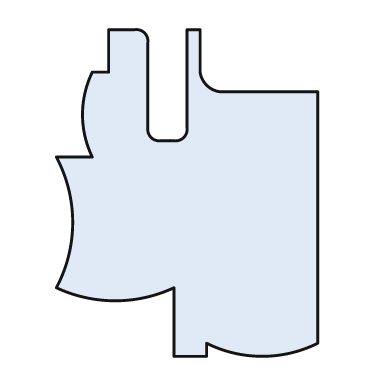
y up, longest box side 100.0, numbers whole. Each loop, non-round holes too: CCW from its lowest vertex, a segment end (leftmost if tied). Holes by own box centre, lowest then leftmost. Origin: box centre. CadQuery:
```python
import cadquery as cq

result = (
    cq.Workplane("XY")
    .moveTo(-4.0, -50.0)
    .lineTo(6.0, -50.0)
    .lineTo(6.0, -46.0)
    .threePointArc((23.0, -50.0), (40.0, -46.0))
    .lineTo(40.0, 31.0)
    .lineTo(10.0, 31.0)
    .threePointArc((6.0, 33.0), (4.0, 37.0))
    .lineTo(4.0, 50.0)
    .lineTo(0.0, 50.0)
    .lineTo(0.0, 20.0)
    .threePointArc((-1.0, 17.0), (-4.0, 16.0))
    .lineTo(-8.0, 16.0)
    .threePointArc((-11.0, 17.0), (-12.0, 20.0))
    .lineTo(-12.0, 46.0)
    .threePointArc((-13.0, 49.0), (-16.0, 50.0))
    .lineTo(-24.0, 50.0)
    .lineTo(-24.0, 37.0)
    .lineTo(-29.0, 37.0)
    .threePointArc((-32.0, 24.0), (-29.0, 11.0))
    .lineTo(-40.0, 11.0)
    .threePointArc((-35.0, -9.0), (-40.0, -29.0))
    .threePointArc((-22.0, -33.0), (-4.0, -29.0))
    .close()
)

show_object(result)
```